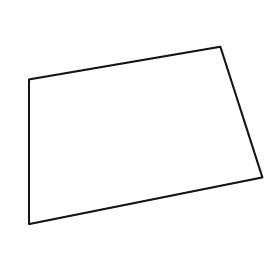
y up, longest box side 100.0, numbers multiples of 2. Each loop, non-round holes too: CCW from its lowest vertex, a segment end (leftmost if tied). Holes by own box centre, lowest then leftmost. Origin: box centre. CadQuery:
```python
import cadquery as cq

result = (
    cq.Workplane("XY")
    .moveTo(-50.0, -38.0)
    .lineTo(50.0, -18.0)
    .lineTo(32.0, 38.0)
    .lineTo(-50.0, 24.0)
    .close()
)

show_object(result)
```